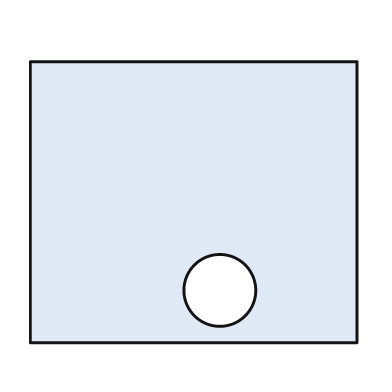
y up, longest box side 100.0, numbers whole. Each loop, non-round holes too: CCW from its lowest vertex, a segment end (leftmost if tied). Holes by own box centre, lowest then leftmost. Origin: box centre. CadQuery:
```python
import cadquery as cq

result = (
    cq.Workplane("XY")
    .moveTo(-50.0, -43.0)
    .lineTo(50.0, -43.0)
    .lineTo(50.0, 43.0)
    .lineTo(-50.0, 43.0)
    .close()
    .moveTo(8.0, -27.0)
    .circle(11.0)
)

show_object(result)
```